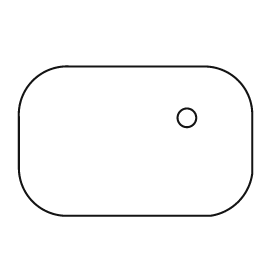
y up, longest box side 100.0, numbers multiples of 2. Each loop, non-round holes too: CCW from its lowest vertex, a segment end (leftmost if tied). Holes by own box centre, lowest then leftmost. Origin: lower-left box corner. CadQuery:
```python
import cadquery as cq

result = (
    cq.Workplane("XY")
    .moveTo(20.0, 0.0)
    .lineTo(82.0, 0.0)
    .threePointArc((94.0, 6.0), (100.0, 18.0))
    .lineTo(100.0, 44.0)
    .threePointArc((94.0, 58.0), (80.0, 64.0))
    .lineTo(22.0, 64.0)
    .threePointArc((6.0, 58.0), (0.0, 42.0))
    .lineTo(0.0, 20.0)
    .threePointArc((6.0, 6.0), (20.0, 0.0))
    .close()
    .moveTo(72.0, 42.0)
    .circle(4.0)
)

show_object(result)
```